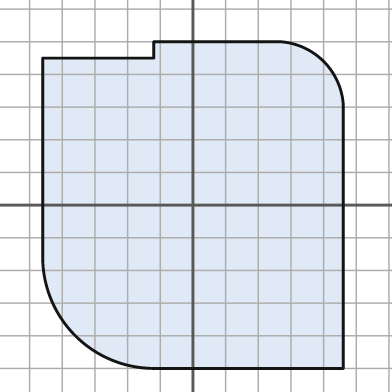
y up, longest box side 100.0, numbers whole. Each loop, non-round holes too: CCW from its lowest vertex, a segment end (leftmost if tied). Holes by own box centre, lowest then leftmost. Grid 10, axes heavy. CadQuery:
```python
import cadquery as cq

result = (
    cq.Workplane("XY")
    .moveTo(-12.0, -50.0)
    .lineTo(46.0, -50.0)
    .lineTo(46.0, 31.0)
    .threePointArc((40.0, 44.0), (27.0, 50.0))
    .lineTo(-12.0, 50.0)
    .lineTo(-12.0, 45.0)
    .lineTo(-46.0, 45.0)
    .lineTo(-46.0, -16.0)
    .threePointArc((-36.0, -40.0), (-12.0, -50.0))
    .close()
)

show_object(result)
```